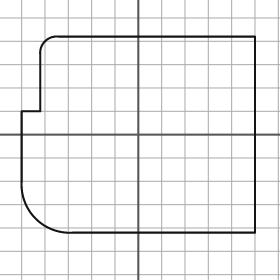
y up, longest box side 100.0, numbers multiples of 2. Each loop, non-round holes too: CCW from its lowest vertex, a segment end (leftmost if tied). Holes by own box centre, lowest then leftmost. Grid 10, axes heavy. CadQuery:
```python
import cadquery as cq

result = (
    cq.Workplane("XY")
    .moveTo(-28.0, -42.0)
    .lineTo(50.0, -42.0)
    .lineTo(50.0, 42.0)
    .lineTo(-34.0, 42.0)
    .threePointArc((-40.0, 40.0), (-42.0, 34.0))
    .lineTo(-42.0, 10.0)
    .lineTo(-50.0, 10.0)
    .lineTo(-50.0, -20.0)
    .threePointArc((-44.0, -36.0), (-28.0, -42.0))
    .close()
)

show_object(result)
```